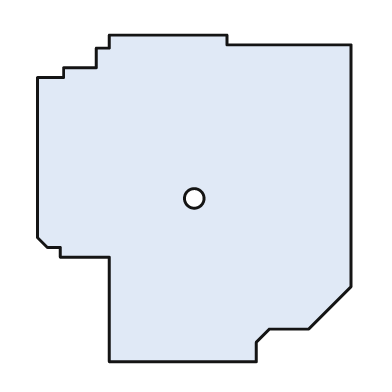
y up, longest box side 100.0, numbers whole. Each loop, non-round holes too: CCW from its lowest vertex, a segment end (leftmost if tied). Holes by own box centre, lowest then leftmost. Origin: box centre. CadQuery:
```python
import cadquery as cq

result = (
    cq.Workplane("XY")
    .moveTo(-26.0, -50.0)
    .lineTo(19.0, -50.0)
    .lineTo(19.0, -44.0)
    .lineTo(23.0, -40.0)
    .lineTo(35.0, -40.0)
    .lineTo(48.0, -27.0)
    .lineTo(48.0, 47.0)
    .lineTo(10.0, 47.0)
    .lineTo(10.0, 50.0)
    .lineTo(-26.0, 50.0)
    .lineTo(-26.0, 46.0)
    .lineTo(-30.0, 46.0)
    .lineTo(-30.0, 40.0)
    .lineTo(-40.0, 40.0)
    .lineTo(-40.0, 37.0)
    .lineTo(-48.0, 37.0)
    .lineTo(-48.0, -12.0)
    .lineTo(-45.0, -15.0)
    .lineTo(-41.0, -15.0)
    .lineTo(-41.0, -18.0)
    .lineTo(-26.0, -18.0)
    .close()
    .moveTo(0.0, 0.0)
    .circle(3.0)
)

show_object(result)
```